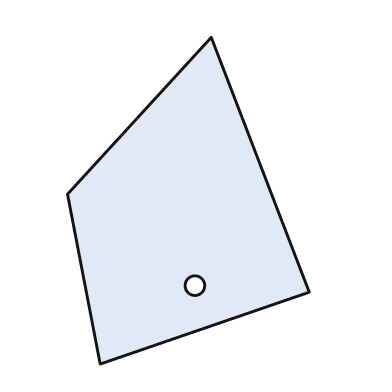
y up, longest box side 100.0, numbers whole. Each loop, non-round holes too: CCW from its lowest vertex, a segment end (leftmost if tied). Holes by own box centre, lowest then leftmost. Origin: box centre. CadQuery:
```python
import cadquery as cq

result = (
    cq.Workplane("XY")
    .moveTo(-27.0, -50.0)
    .lineTo(37.0, -28.0)
    .lineTo(7.0, 50.0)
    .lineTo(-37.0, 2.0)
    .close()
    .moveTo(2.0, -26.0)
    .circle(3.0)
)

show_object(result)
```